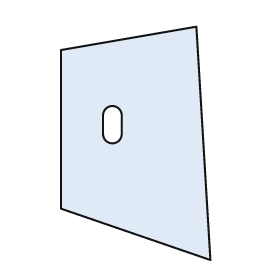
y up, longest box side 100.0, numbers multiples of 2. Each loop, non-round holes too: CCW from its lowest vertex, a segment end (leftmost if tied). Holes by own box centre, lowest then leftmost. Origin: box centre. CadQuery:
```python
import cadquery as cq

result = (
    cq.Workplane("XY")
    .moveTo(32.0, -50.0)
    .lineTo(26.0, 50.0)
    .lineTo(-32.0, 40.0)
    .lineTo(-32.0, -28.0)
    .close()
    .moveTo(-14.0, 4.0)
    .threePointArc((-10.0, 0.0), (-6.0, 4.0))
    .lineTo(-6.0, 12.0)
    .threePointArc((-10.0, 16.0), (-14.0, 12.0))
    .close()
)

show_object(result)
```